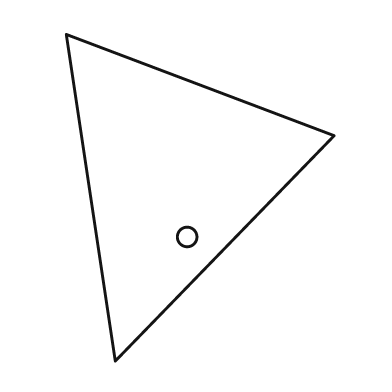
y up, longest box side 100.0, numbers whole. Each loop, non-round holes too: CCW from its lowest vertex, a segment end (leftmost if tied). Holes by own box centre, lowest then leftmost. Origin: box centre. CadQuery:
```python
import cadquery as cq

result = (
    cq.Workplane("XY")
    .moveTo(-26.0, -50.0)
    .lineTo(41.0, 19.0)
    .lineTo(-41.0, 50.0)
    .close()
    .moveTo(-4.0, -12.0)
    .circle(3.0)
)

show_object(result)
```